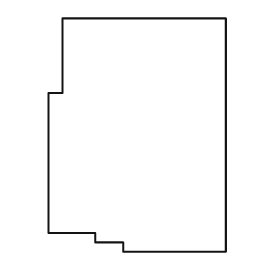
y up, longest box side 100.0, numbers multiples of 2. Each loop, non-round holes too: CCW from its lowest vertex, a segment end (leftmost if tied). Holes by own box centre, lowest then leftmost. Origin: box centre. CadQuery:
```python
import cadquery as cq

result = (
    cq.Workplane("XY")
    .moveTo(-6.0, -50.0)
    .lineTo(38.0, -50.0)
    .lineTo(38.0, 50.0)
    .lineTo(-32.0, 50.0)
    .lineTo(-32.0, 18.0)
    .lineTo(-38.0, 18.0)
    .lineTo(-38.0, -42.0)
    .lineTo(-18.0, -42.0)
    .lineTo(-18.0, -46.0)
    .lineTo(-6.0, -46.0)
    .close()
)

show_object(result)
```